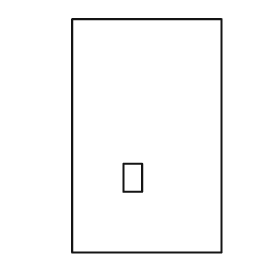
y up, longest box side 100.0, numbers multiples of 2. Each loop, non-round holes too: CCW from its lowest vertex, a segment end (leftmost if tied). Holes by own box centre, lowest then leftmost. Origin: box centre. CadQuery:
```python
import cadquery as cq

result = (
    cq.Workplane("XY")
    .moveTo(-32.0, -50.0)
    .lineTo(32.0, -50.0)
    .lineTo(32.0, 50.0)
    .lineTo(-32.0, 50.0)
    .close()
    .moveTo(-10.0, -24.0)
    .lineTo(-2.0, -24.0)
    .lineTo(-2.0, -12.0)
    .lineTo(-10.0, -12.0)
    .close()
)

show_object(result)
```